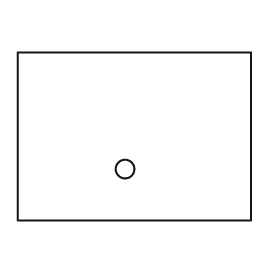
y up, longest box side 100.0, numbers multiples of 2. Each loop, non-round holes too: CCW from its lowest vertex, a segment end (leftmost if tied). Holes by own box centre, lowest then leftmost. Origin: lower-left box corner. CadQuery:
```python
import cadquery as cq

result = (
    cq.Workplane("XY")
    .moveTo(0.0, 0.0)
    .lineTo(100.0, 0.0)
    .lineTo(100.0, 72.0)
    .lineTo(0.0, 72.0)
    .close()
    .moveTo(46.0, 22.0)
    .circle(4.0)
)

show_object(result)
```